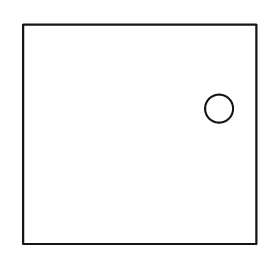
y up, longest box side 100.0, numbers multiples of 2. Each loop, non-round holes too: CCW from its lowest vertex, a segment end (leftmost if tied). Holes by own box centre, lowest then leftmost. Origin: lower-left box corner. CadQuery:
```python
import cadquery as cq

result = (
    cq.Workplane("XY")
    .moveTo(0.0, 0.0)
    .lineTo(100.0, 0.0)
    .lineTo(100.0, 94.0)
    .lineTo(0.0, 94.0)
    .close()
    .moveTo(84.0, 58.0)
    .circle(6.0)
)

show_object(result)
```